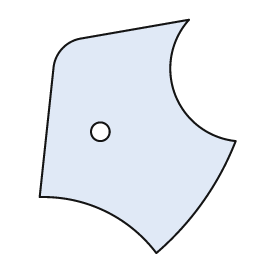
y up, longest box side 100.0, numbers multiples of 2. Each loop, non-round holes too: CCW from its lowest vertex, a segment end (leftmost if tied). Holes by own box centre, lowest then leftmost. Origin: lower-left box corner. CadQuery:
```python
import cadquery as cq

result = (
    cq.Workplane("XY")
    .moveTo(50.0, 0.0)
    .threePointArc((70.0, 22.0), (84.0, 48.0))
    .threePointArc((58.0, 68.0), (64.0, 100.0))
    .lineTo(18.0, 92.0)
    .threePointArc((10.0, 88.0), (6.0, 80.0))
    .lineTo(0.0, 24.0)
    .threePointArc((28.0, 18.0), (50.0, 0.0))
    .close()
    .moveTo(26.0, 52.0)
    .circle(4.0)
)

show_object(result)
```